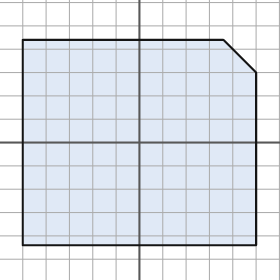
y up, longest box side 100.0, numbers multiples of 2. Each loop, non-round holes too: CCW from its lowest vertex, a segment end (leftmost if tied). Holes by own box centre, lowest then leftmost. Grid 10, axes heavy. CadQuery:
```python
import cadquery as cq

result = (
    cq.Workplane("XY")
    .moveTo(-50.0, -44.0)
    .lineTo(50.0, -44.0)
    .lineTo(50.0, 30.0)
    .lineTo(36.0, 44.0)
    .lineTo(-50.0, 44.0)
    .close()
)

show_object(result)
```